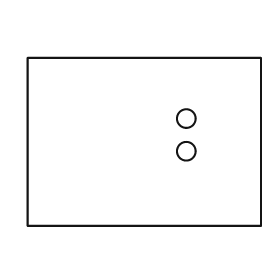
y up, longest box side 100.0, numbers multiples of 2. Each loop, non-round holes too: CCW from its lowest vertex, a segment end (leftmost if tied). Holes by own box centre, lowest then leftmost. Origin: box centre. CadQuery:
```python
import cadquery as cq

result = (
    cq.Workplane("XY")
    .moveTo(-50.0, -36.0)
    .lineTo(50.0, -36.0)
    .lineTo(50.0, 36.0)
    .lineTo(-50.0, 36.0)
    .close()
    .moveTo(18.0, -4.0)
    .circle(4.0)
    .moveTo(18.0, 10.0)
    .circle(4.0)
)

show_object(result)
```